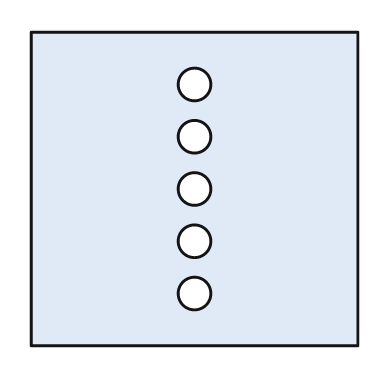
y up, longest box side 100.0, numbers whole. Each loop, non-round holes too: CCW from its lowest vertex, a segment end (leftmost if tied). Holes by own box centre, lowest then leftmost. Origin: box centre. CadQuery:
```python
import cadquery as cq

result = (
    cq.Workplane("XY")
    .moveTo(-50.0, -48.0)
    .lineTo(50.0, -48.0)
    .lineTo(50.0, 48.0)
    .lineTo(-50.0, 48.0)
    .close()
    .moveTo(0.0, -32.0)
    .circle(5.0)
    .moveTo(0.0, -16.0)
    .circle(5.0)
    .moveTo(0.0, 0.0)
    .circle(5.0)
    .moveTo(0.0, 16.0)
    .circle(5.0)
    .moveTo(0.0, 32.0)
    .circle(5.0)
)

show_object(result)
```